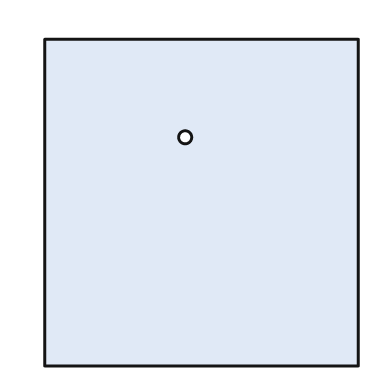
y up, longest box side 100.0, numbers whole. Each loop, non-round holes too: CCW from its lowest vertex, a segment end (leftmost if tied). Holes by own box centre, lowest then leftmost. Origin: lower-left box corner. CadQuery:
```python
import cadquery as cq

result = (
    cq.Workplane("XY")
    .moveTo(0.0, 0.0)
    .lineTo(96.0, 0.0)
    .lineTo(96.0, 100.0)
    .lineTo(0.0, 100.0)
    .close()
    .moveTo(43.0, 70.0)
    .circle(2.0)
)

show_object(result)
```